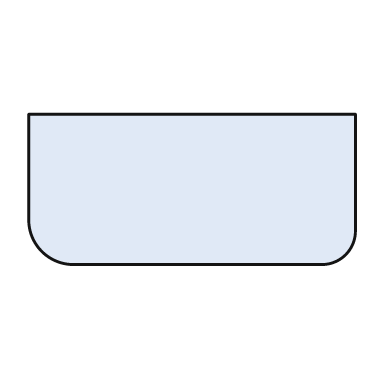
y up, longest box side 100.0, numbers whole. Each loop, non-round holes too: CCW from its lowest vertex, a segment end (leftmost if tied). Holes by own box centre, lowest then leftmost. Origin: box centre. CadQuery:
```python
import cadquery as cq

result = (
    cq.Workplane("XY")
    .moveTo(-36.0, -23.0)
    .lineTo(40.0, -23.0)
    .threePointArc((47.0, -20.0), (50.0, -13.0))
    .lineTo(50.0, 23.0)
    .lineTo(-50.0, 23.0)
    .lineTo(-50.0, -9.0)
    .threePointArc((-46.0, -19.0), (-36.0, -23.0))
    .close()
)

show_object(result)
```